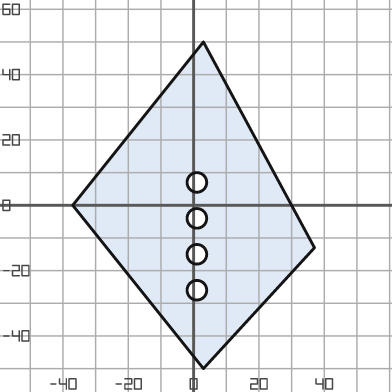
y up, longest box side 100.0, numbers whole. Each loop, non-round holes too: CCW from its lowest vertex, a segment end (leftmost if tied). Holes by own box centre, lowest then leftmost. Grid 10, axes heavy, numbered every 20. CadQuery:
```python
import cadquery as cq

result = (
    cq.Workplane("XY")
    .moveTo(3.0, -50.0)
    .lineTo(37.0, -13.0)
    .lineTo(3.0, 50.0)
    .lineTo(-37.0, 0.0)
    .close()
    .moveTo(1.0, -26.0)
    .circle(3.0)
    .moveTo(1.0, -15.0)
    .circle(3.0)
    .moveTo(1.0, -4.0)
    .circle(3.0)
    .moveTo(1.0, 7.0)
    .circle(3.0)
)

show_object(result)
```